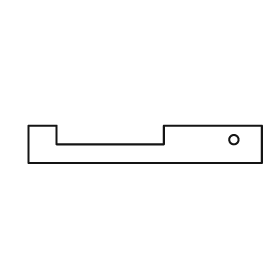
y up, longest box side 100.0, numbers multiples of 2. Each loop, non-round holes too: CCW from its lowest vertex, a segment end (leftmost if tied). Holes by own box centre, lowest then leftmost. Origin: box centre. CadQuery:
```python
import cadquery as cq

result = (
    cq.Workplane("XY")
    .moveTo(-50.0, -8.0)
    .lineTo(50.0, -8.0)
    .lineTo(50.0, 8.0)
    .lineTo(8.0, 8.0)
    .lineTo(8.0, 0.0)
    .lineTo(-38.0, 0.0)
    .lineTo(-38.0, 8.0)
    .lineTo(-50.0, 8.0)
    .close()
    .moveTo(38.0, 2.0)
    .circle(2.0)
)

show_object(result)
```